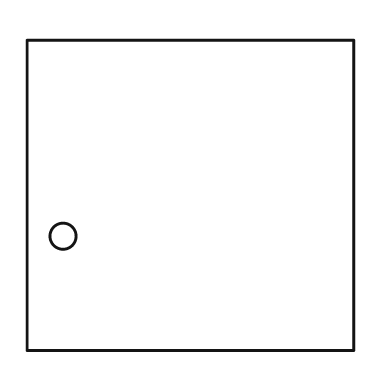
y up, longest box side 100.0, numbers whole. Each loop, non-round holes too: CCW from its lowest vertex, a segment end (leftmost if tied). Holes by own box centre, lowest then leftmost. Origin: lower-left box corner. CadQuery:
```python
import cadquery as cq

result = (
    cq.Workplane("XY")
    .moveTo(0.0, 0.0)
    .lineTo(100.0, 0.0)
    .lineTo(100.0, 95.0)
    .lineTo(0.0, 95.0)
    .close()
    .moveTo(11.0, 35.0)
    .circle(4.0)
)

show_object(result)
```